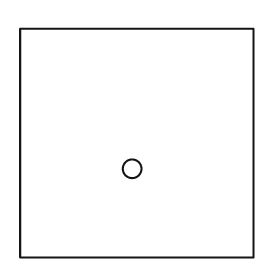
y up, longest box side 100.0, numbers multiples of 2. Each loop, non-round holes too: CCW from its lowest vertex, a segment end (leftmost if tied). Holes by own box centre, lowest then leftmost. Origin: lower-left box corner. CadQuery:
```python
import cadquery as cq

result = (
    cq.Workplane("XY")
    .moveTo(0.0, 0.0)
    .lineTo(100.0, 0.0)
    .lineTo(100.0, 98.0)
    .lineTo(0.0, 98.0)
    .close()
    .moveTo(48.0, 38.0)
    .circle(4.0)
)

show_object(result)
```